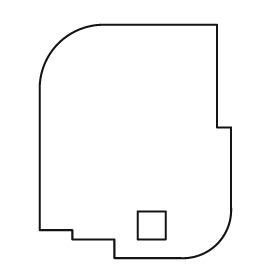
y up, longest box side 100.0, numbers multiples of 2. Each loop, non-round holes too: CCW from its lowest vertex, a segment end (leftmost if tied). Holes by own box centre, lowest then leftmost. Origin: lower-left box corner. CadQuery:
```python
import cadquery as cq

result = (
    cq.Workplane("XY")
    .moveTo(32.0, 0.0)
    .lineTo(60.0, 0.0)
    .threePointArc((76.0, 6.0), (82.0, 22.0))
    .lineTo(82.0, 56.0)
    .lineTo(76.0, 56.0)
    .lineTo(76.0, 100.0)
    .lineTo(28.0, 100.0)
    .threePointArc((8.0, 92.0), (0.0, 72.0))
    .lineTo(0.0, 12.0)
    .lineTo(14.0, 12.0)
    .lineTo(14.0, 8.0)
    .lineTo(32.0, 8.0)
    .close()
    .moveTo(42.0, 8.0)
    .lineTo(54.0, 8.0)
    .lineTo(54.0, 20.0)
    .lineTo(42.0, 20.0)
    .close()
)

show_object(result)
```